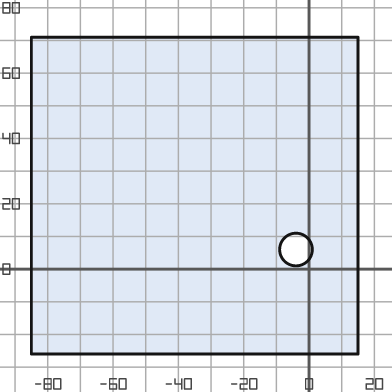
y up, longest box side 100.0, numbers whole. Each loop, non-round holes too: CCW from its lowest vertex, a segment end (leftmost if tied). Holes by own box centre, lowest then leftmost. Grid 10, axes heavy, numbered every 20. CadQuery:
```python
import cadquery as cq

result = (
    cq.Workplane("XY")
    .moveTo(-85.0, -26.0)
    .lineTo(15.0, -26.0)
    .lineTo(15.0, 71.0)
    .lineTo(-85.0, 71.0)
    .close()
    .moveTo(-4.0, 6.0)
    .circle(5.0)
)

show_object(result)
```